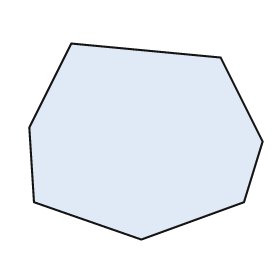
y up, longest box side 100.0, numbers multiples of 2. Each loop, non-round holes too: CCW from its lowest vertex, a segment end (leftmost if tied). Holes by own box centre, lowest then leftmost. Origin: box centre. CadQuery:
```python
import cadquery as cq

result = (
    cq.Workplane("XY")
    .moveTo(-2.0, -42.0)
    .lineTo(42.0, -26.0)
    .lineTo(50.0, 0.0)
    .lineTo(32.0, 36.0)
    .lineTo(-32.0, 42.0)
    .lineTo(-50.0, 6.0)
    .lineTo(-48.0, -26.0)
    .close()
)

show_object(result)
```